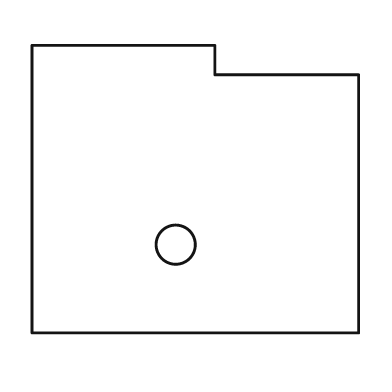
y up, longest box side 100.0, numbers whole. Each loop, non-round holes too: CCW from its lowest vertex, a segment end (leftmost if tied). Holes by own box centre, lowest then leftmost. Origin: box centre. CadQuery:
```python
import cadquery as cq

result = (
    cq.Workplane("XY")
    .moveTo(-50.0, -44.0)
    .lineTo(50.0, -44.0)
    .lineTo(50.0, 35.0)
    .lineTo(6.0, 35.0)
    .lineTo(6.0, 44.0)
    .lineTo(-50.0, 44.0)
    .close()
    .moveTo(-6.0, -17.0)
    .circle(6.0)
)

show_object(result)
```